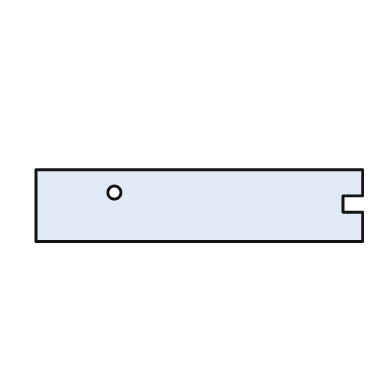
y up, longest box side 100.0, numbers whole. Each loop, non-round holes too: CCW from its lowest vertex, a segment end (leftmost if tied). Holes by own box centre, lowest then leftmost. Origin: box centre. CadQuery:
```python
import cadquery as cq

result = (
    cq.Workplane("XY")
    .moveTo(-50.0, -11.0)
    .lineTo(50.0, -11.0)
    .lineTo(50.0, -2.0)
    .lineTo(44.0, -2.0)
    .lineTo(44.0, 3.0)
    .lineTo(50.0, 3.0)
    .lineTo(50.0, 11.0)
    .lineTo(-50.0, 11.0)
    .close()
    .moveTo(-26.0, 4.0)
    .circle(2.0)
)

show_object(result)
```